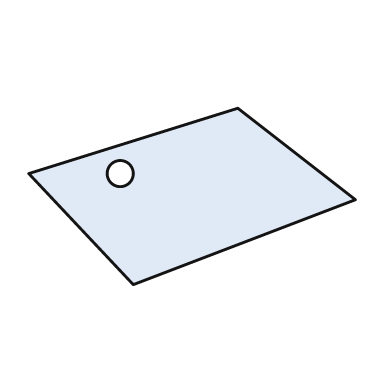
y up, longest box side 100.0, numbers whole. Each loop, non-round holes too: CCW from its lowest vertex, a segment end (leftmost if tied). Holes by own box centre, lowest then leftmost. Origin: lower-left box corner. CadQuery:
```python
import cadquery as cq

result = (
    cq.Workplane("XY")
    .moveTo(32.0, 0.0)
    .lineTo(100.0, 26.0)
    .lineTo(64.0, 54.0)
    .lineTo(0.0, 34.0)
    .close()
    .moveTo(28.0, 34.0)
    .circle(4.0)
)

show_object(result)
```